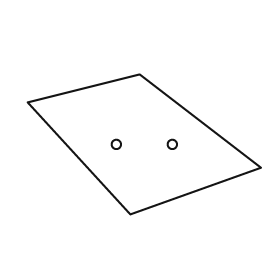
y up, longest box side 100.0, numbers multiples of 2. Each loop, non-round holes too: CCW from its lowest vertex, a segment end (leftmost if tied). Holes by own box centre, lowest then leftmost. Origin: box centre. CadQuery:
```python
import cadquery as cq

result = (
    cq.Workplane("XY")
    .moveTo(-6.0, -30.0)
    .lineTo(50.0, -10.0)
    .lineTo(-2.0, 30.0)
    .lineTo(-50.0, 18.0)
    .close()
    .moveTo(-12.0, 0.0)
    .circle(2.0)
    .moveTo(12.0, 0.0)
    .circle(2.0)
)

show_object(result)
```